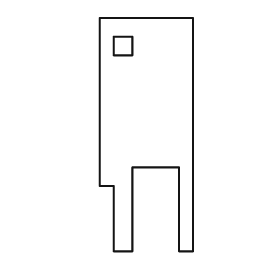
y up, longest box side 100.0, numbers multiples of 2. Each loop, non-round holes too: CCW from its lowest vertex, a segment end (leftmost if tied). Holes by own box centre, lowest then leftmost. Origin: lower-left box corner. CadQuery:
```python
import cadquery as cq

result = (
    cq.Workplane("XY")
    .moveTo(6.0, 0.0)
    .lineTo(14.0, 0.0)
    .lineTo(14.0, 36.0)
    .lineTo(34.0, 36.0)
    .lineTo(34.0, 0.0)
    .lineTo(40.0, 0.0)
    .lineTo(40.0, 100.0)
    .lineTo(0.0, 100.0)
    .lineTo(0.0, 28.0)
    .lineTo(6.0, 28.0)
    .close()
    .moveTo(6.0, 84.0)
    .lineTo(14.0, 84.0)
    .lineTo(14.0, 92.0)
    .lineTo(6.0, 92.0)
    .close()
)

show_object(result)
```